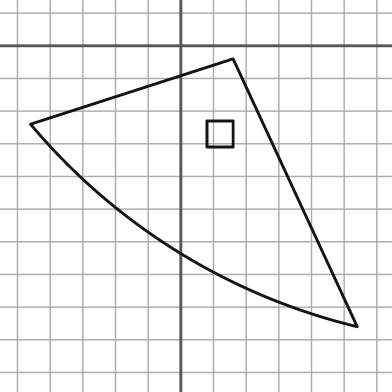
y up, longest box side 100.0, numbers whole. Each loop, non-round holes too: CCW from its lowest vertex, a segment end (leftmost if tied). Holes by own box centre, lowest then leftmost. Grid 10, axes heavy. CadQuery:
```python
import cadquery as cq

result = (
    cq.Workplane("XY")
    .moveTo(54.0, -86.0)
    .lineTo(16.0, -4.0)
    .lineTo(-46.0, -24.0)
    .threePointArc((-1.0, -63.0), (54.0, -86.0))
    .close()
    .moveTo(8.0, -31.0)
    .lineTo(16.0, -31.0)
    .lineTo(16.0, -23.0)
    .lineTo(8.0, -23.0)
    .close()
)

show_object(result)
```